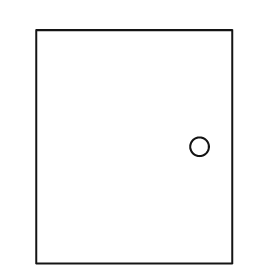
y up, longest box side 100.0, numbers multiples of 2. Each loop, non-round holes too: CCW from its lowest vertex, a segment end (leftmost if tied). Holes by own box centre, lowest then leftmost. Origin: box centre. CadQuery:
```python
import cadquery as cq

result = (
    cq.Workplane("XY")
    .moveTo(-42.0, -50.0)
    .lineTo(42.0, -50.0)
    .lineTo(42.0, 50.0)
    .lineTo(-42.0, 50.0)
    .close()
    .moveTo(28.0, 0.0)
    .circle(4.0)
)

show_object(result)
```